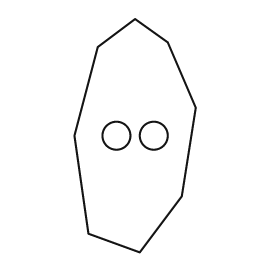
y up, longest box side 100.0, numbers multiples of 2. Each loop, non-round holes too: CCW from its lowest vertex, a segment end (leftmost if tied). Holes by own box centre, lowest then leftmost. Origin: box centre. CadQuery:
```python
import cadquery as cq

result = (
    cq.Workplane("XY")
    .moveTo(2.0, -50.0)
    .lineTo(20.0, -26.0)
    .lineTo(26.0, 12.0)
    .lineTo(14.0, 40.0)
    .lineTo(0.0, 50.0)
    .lineTo(-16.0, 38.0)
    .lineTo(-26.0, 0.0)
    .lineTo(-20.0, -42.0)
    .close()
    .moveTo(-8.0, 0.0)
    .circle(6.0)
    .moveTo(8.0, 0.0)
    .circle(6.0)
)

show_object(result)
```